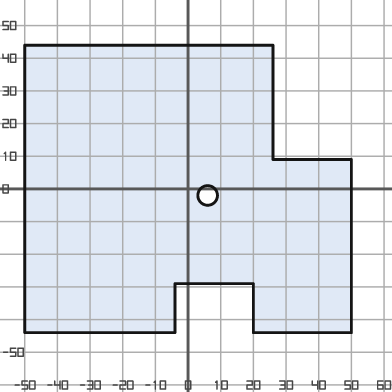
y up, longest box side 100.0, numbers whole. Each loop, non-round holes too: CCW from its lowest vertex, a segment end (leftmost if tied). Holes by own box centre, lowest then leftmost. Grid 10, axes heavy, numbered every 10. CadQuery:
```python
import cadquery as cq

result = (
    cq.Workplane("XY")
    .moveTo(-50.0, -44.0)
    .lineTo(-4.0, -44.0)
    .lineTo(-4.0, -29.0)
    .lineTo(20.0, -29.0)
    .lineTo(20.0, -44.0)
    .lineTo(50.0, -44.0)
    .lineTo(50.0, 9.0)
    .lineTo(26.0, 9.0)
    .lineTo(26.0, 44.0)
    .lineTo(-50.0, 44.0)
    .close()
    .moveTo(6.0, -2.0)
    .circle(3.0)
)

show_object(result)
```